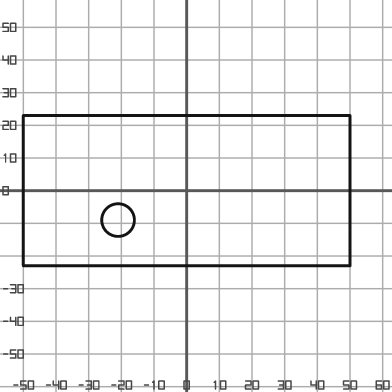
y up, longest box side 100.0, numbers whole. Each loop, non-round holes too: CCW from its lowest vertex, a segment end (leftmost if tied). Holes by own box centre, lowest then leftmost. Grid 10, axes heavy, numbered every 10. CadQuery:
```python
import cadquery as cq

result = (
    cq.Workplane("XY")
    .moveTo(-50.0, -23.0)
    .lineTo(50.0, -23.0)
    .lineTo(50.0, 23.0)
    .lineTo(-50.0, 23.0)
    .close()
    .moveTo(-21.0, -9.0)
    .circle(5.0)
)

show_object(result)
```